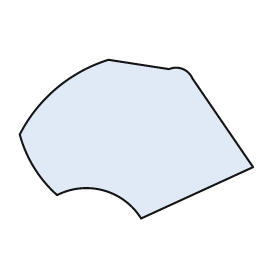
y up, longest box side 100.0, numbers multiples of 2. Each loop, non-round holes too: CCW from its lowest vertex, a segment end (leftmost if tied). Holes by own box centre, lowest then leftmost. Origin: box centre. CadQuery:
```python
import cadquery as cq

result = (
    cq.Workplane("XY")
    .moveTo(2.0, -34.0)
    .lineTo(50.0, -12.0)
    .lineTo(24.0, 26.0)
    .threePointArc((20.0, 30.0), (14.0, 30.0))
    .lineTo(-12.0, 34.0)
    .threePointArc((-34.0, 22.0), (-50.0, 2.0))
    .threePointArc((-44.0, -12.0), (-34.0, -24.0))
    .threePointArc((-14.0, -22.0), (2.0, -34.0))
    .close()
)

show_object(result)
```